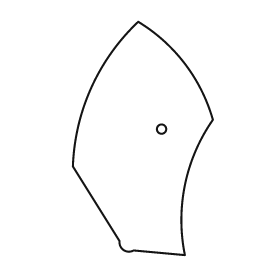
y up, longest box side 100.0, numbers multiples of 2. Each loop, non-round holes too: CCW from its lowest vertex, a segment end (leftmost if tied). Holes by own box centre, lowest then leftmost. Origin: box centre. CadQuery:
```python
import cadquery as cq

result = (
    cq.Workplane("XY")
    .moveTo(18.0, -50.0)
    .threePointArc((18.0, -20.0), (30.0, 8.0))
    .threePointArc((18.0, 32.0), (-2.0, 50.0))
    .threePointArc((-22.0, 22.0), (-30.0, -12.0))
    .lineTo(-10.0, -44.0)
    .threePointArc((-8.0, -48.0), (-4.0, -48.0))
    .close()
    .moveTo(8.0, 4.0)
    .circle(2.0)
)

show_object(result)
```